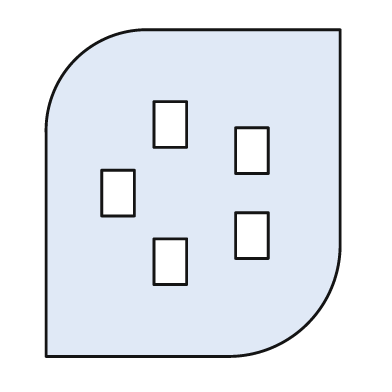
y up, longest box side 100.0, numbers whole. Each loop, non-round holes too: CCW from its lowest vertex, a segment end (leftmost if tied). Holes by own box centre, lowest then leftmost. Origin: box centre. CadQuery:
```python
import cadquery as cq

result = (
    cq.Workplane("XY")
    .moveTo(-45.0, -50.0)
    .lineTo(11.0, -50.0)
    .threePointArc((35.0, -40.0), (45.0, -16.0))
    .lineTo(45.0, 50.0)
    .lineTo(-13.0, 50.0)
    .threePointArc((-36.0, 41.0), (-45.0, 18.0))
    .close()
    .moveTo(-12.0, -28.0)
    .lineTo(-2.0, -28.0)
    .lineTo(-2.0, -14.0)
    .lineTo(-12.0, -14.0)
    .close()
    .moveTo(13.0, -20.0)
    .lineTo(23.0, -20.0)
    .lineTo(23.0, -6.0)
    .lineTo(13.0, -6.0)
    .close()
    .moveTo(-28.0, -7.0)
    .lineTo(-18.0, -7.0)
    .lineTo(-18.0, 7.0)
    .lineTo(-28.0, 7.0)
    .close()
    .moveTo(13.0, 6.0)
    .lineTo(23.0, 6.0)
    .lineTo(23.0, 20.0)
    .lineTo(13.0, 20.0)
    .close()
    .moveTo(-12.0, 14.0)
    .lineTo(-2.0, 14.0)
    .lineTo(-2.0, 28.0)
    .lineTo(-12.0, 28.0)
    .close()
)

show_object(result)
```